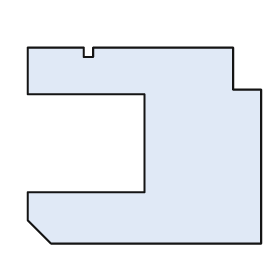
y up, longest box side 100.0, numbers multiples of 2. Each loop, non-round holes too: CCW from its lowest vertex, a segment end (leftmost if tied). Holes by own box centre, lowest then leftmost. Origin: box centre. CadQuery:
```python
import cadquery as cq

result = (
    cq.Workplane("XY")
    .moveTo(-40.0, -42.0)
    .lineTo(50.0, -42.0)
    .lineTo(50.0, 24.0)
    .lineTo(38.0, 24.0)
    .lineTo(38.0, 42.0)
    .lineTo(-22.0, 42.0)
    .lineTo(-22.0, 38.0)
    .lineTo(-26.0, 38.0)
    .lineTo(-26.0, 42.0)
    .lineTo(-50.0, 42.0)
    .lineTo(-50.0, 22.0)
    .lineTo(0.0, 22.0)
    .lineTo(0.0, -20.0)
    .lineTo(-50.0, -20.0)
    .lineTo(-50.0, -32.0)
    .close()
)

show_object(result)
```